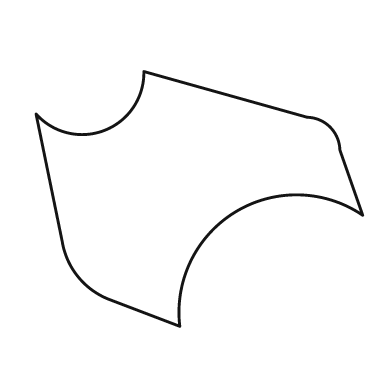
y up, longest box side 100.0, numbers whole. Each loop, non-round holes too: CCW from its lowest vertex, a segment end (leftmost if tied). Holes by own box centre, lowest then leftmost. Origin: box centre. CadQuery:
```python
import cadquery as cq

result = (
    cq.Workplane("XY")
    .moveTo(-6.0, -39.0)
    .threePointArc((11.0, -4.0), (50.0, -5.0))
    .lineTo(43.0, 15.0)
    .threePointArc((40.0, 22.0), (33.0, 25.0))
    .lineTo(-17.0, 39.0)
    .threePointArc((-29.0, 21.0), (-50.0, 26.0))
    .lineTo(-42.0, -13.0)
    .threePointArc((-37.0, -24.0), (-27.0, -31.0))
    .close()
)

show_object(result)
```